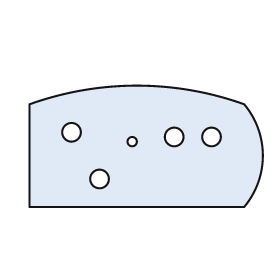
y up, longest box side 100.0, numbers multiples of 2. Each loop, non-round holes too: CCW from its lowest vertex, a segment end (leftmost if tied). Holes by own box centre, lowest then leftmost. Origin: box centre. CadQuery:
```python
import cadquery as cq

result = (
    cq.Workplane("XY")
    .moveTo(-50.0, -26.0)
    .lineTo(42.0, -26.0)
    .threePointArc((50.0, -4.0), (42.0, 18.0))
    .threePointArc((-4.0, 26.0), (-50.0, 18.0))
    .close()
    .moveTo(-20.0, -14.0)
    .circle(4.0)
    .moveTo(-6.0, 2.0)
    .circle(2.0)
    .moveTo(12.0, 4.0)
    .circle(4.0)
    .moveTo(28.0, 4.0)
    .circle(4.0)
    .moveTo(-32.0, 6.0)
    .circle(4.0)
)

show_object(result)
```